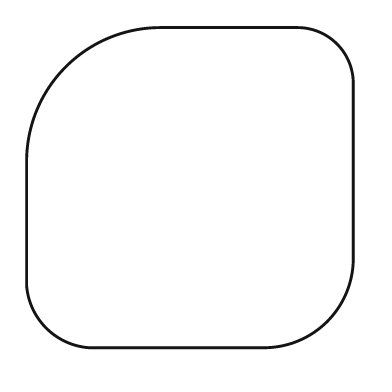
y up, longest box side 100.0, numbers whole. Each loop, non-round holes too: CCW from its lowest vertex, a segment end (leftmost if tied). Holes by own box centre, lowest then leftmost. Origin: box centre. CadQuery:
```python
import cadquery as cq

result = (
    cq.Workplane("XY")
    .moveTo(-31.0, -49.0)
    .lineTo(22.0, -49.0)
    .threePointArc((42.0, -41.0), (50.0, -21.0))
    .lineTo(50.0, 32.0)
    .threePointArc((45.0, 44.0), (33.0, 49.0))
    .lineTo(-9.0, 49.0)
    .threePointArc((-38.0, 37.0), (-50.0, 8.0))
    .lineTo(-50.0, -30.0)
    .threePointArc((-44.0, -43.0), (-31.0, -49.0))
    .close()
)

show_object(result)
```